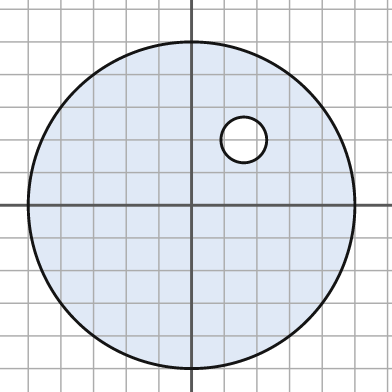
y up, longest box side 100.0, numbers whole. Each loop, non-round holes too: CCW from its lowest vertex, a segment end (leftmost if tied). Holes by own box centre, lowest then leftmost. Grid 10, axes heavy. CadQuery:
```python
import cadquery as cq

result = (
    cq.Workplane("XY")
    .moveTo(0.0, 0.0)
    .circle(50.0)
    .moveTo(16.0, 20.0)
    .circle(7.0)
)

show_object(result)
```